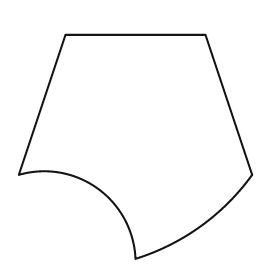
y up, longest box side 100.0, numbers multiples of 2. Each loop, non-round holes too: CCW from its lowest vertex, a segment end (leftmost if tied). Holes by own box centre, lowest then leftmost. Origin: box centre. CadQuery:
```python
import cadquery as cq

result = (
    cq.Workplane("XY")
    .moveTo(0.0, -48.0)
    .threePointArc((28.0, -34.0), (50.0, -12.0))
    .lineTo(30.0, 48.0)
    .lineTo(-30.0, 48.0)
    .lineTo(-50.0, -12.0)
    .threePointArc((-16.0, -18.0), (0.0, -48.0))
    .close()
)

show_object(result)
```